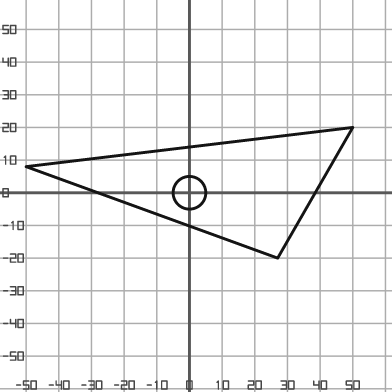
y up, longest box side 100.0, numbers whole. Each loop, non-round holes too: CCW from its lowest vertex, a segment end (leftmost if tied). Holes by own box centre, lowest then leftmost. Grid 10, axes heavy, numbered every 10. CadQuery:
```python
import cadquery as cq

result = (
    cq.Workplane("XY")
    .moveTo(27.0, -20.0)
    .lineTo(50.0, 20.0)
    .lineTo(-50.0, 8.0)
    .close()
    .moveTo(0.0, 0.0)
    .circle(5.0)
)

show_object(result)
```